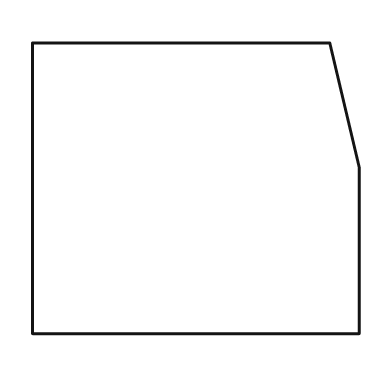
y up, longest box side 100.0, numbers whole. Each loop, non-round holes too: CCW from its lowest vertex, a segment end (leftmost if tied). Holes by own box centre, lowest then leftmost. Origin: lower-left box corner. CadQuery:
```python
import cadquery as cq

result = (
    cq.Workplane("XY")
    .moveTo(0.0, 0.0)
    .lineTo(100.0, 0.0)
    .lineTo(100.0, 51.0)
    .lineTo(91.0, 89.0)
    .lineTo(0.0, 89.0)
    .close()
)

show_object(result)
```